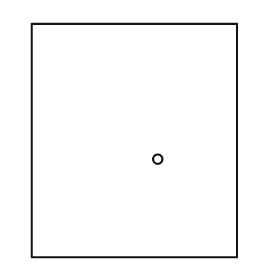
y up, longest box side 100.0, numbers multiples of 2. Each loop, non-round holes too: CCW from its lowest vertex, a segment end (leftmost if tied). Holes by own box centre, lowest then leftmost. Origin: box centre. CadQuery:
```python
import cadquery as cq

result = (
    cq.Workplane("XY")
    .moveTo(-44.0, -50.0)
    .lineTo(44.0, -50.0)
    .lineTo(44.0, 50.0)
    .lineTo(-44.0, 50.0)
    .close()
    .moveTo(10.0, -8.0)
    .circle(2.0)
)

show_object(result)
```